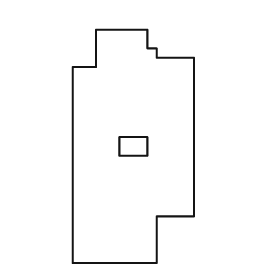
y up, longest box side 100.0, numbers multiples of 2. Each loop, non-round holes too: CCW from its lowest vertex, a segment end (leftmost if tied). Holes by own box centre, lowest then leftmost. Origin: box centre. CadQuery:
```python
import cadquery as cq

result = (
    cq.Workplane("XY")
    .moveTo(-26.0, -50.0)
    .lineTo(10.0, -50.0)
    .lineTo(10.0, -30.0)
    .lineTo(26.0, -30.0)
    .lineTo(26.0, 38.0)
    .lineTo(10.0, 38.0)
    .lineTo(10.0, 42.0)
    .lineTo(6.0, 42.0)
    .lineTo(6.0, 50.0)
    .lineTo(-16.0, 50.0)
    .lineTo(-16.0, 34.0)
    .lineTo(-26.0, 34.0)
    .close()
    .moveTo(-6.0, -4.0)
    .lineTo(6.0, -4.0)
    .lineTo(6.0, 4.0)
    .lineTo(-6.0, 4.0)
    .close()
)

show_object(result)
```